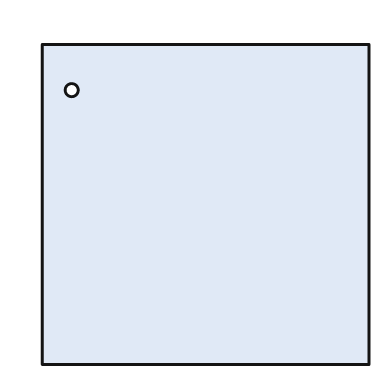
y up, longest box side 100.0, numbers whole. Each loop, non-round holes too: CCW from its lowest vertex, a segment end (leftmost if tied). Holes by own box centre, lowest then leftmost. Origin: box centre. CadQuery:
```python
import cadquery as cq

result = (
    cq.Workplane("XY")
    .moveTo(-50.0, -49.0)
    .lineTo(50.0, -49.0)
    .lineTo(50.0, 49.0)
    .lineTo(-50.0, 49.0)
    .close()
    .moveTo(-41.0, 35.0)
    .circle(2.0)
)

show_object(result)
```